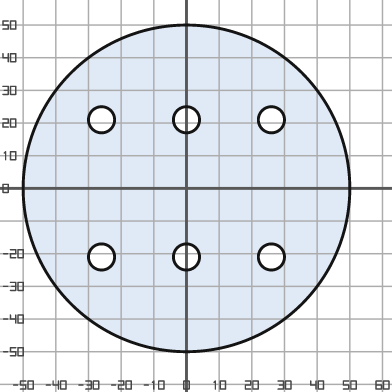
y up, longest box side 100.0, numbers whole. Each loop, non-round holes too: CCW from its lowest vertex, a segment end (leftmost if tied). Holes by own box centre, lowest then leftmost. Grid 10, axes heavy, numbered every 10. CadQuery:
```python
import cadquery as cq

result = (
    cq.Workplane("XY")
    .moveTo(0.0, 0.0)
    .circle(50.0)
    .moveTo(-26.0, -21.0)
    .circle(4.0)
    .moveTo(0.0, -21.0)
    .circle(4.0)
    .moveTo(26.0, -21.0)
    .circle(4.0)
    .moveTo(-26.0, 21.0)
    .circle(4.0)
    .moveTo(0.0, 21.0)
    .circle(4.0)
    .moveTo(26.0, 21.0)
    .circle(4.0)
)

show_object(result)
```